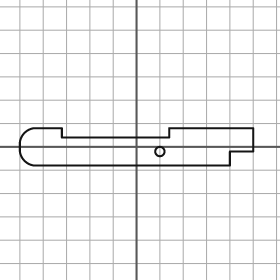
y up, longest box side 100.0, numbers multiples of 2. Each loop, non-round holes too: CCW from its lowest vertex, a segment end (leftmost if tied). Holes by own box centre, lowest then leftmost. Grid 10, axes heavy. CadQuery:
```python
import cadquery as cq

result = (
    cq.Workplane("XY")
    .moveTo(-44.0, -8.0)
    .lineTo(40.0, -8.0)
    .lineTo(40.0, -2.0)
    .lineTo(50.0, -2.0)
    .lineTo(50.0, 8.0)
    .lineTo(14.0, 8.0)
    .lineTo(14.0, 4.0)
    .lineTo(-32.0, 4.0)
    .lineTo(-32.0, 8.0)
    .lineTo(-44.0, 8.0)
    .threePointArc((-48.0, 6.0), (-50.0, 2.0))
    .lineTo(-50.0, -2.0)
    .threePointArc((-48.0, -6.0), (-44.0, -8.0))
    .close()
    .moveTo(10.0, -2.0)
    .circle(2.0)
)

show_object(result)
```